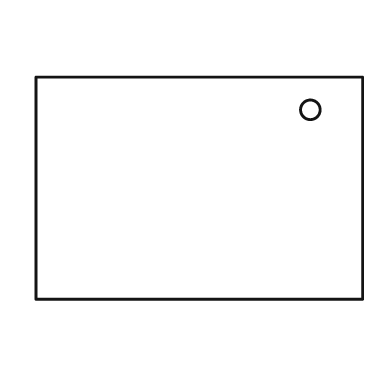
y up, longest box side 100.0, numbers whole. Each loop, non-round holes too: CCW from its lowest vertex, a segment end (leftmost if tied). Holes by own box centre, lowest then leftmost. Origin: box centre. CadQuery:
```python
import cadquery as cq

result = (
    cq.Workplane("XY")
    .moveTo(-50.0, -34.0)
    .lineTo(50.0, -34.0)
    .lineTo(50.0, 34.0)
    .lineTo(-50.0, 34.0)
    .close()
    .moveTo(34.0, 24.0)
    .circle(3.0)
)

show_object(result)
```